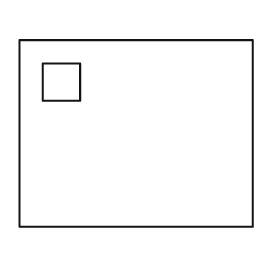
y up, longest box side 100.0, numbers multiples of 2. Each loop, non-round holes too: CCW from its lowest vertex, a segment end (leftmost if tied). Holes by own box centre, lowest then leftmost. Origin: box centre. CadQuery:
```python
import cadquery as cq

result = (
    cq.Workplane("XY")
    .moveTo(-50.0, -40.0)
    .lineTo(50.0, -40.0)
    .lineTo(50.0, 40.0)
    .lineTo(-50.0, 40.0)
    .close()
    .moveTo(-40.0, 14.0)
    .lineTo(-24.0, 14.0)
    .lineTo(-24.0, 30.0)
    .lineTo(-40.0, 30.0)
    .close()
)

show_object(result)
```